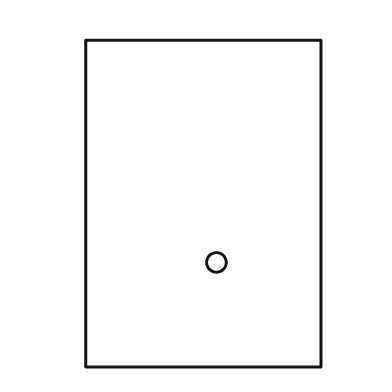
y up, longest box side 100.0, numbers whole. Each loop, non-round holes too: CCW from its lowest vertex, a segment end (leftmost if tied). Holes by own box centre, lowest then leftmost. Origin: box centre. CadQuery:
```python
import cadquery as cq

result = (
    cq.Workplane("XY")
    .moveTo(-36.0, -50.0)
    .lineTo(36.0, -50.0)
    .lineTo(36.0, 50.0)
    .lineTo(-36.0, 50.0)
    .close()
    .moveTo(4.0, -18.0)
    .circle(3.0)
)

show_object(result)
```